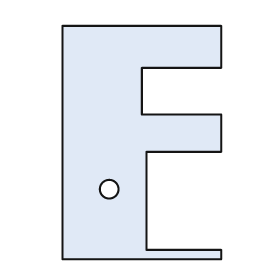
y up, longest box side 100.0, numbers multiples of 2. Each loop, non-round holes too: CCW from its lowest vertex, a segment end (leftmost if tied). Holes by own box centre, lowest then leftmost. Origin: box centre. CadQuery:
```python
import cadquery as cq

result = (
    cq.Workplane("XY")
    .moveTo(-34.0, -50.0)
    .lineTo(34.0, -50.0)
    .lineTo(34.0, -46.0)
    .lineTo(2.0, -46.0)
    .lineTo(2.0, -4.0)
    .lineTo(34.0, -4.0)
    .lineTo(34.0, 12.0)
    .lineTo(0.0, 12.0)
    .lineTo(0.0, 32.0)
    .lineTo(34.0, 32.0)
    .lineTo(34.0, 50.0)
    .lineTo(-34.0, 50.0)
    .close()
    .moveTo(-14.0, -20.0)
    .circle(4.0)
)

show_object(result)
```